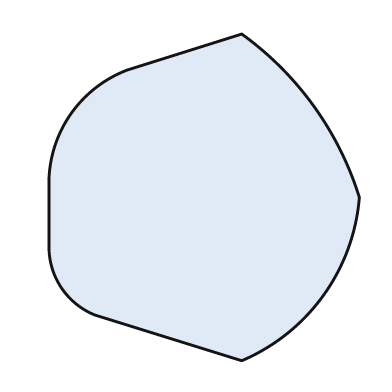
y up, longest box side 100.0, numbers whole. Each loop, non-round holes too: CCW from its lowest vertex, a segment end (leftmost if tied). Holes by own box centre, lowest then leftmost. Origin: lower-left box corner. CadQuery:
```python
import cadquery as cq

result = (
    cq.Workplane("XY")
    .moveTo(59.0, 0.0)
    .threePointArc((84.0, 20.0), (95.0, 50.0))
    .threePointArc((81.0, 78.0), (59.0, 100.0))
    .lineTo(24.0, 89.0)
    .threePointArc((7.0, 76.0), (0.0, 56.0))
    .lineTo(0.0, 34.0)
    .threePointArc((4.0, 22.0), (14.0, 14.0))
    .close()
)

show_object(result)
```